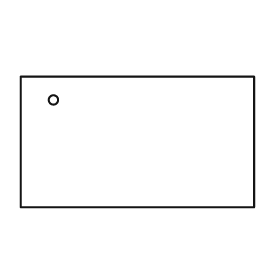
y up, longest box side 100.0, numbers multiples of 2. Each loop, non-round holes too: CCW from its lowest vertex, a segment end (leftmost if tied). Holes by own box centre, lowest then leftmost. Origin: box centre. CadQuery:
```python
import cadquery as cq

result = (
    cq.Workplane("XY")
    .moveTo(-50.0, -28.0)
    .lineTo(50.0, -28.0)
    .lineTo(50.0, 28.0)
    .lineTo(-50.0, 28.0)
    .close()
    .moveTo(-36.0, 18.0)
    .circle(2.0)
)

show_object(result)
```